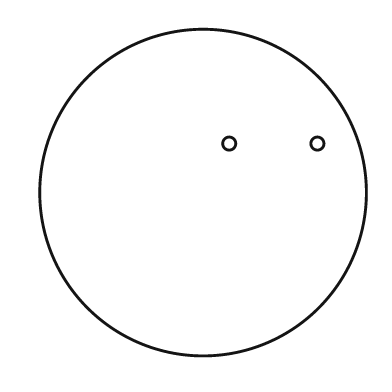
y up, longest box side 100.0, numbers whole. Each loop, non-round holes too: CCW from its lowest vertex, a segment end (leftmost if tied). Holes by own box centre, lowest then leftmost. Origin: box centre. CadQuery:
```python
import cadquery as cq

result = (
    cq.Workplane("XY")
    .moveTo(0.0, 0.0)
    .circle(50.0)
    .moveTo(8.0, 15.0)
    .circle(2.0)
    .moveTo(35.0, 15.0)
    .circle(2.0)
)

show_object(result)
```